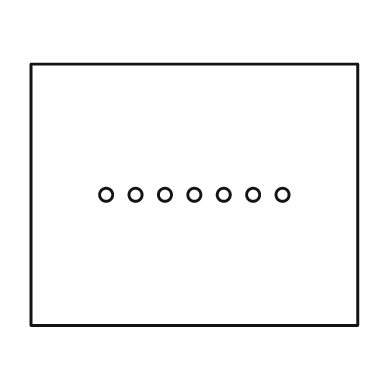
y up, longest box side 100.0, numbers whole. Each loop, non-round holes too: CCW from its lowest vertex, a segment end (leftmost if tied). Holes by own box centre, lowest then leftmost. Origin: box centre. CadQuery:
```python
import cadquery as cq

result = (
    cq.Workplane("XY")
    .moveTo(-50.0, -40.0)
    .lineTo(50.0, -40.0)
    .lineTo(50.0, 40.0)
    .lineTo(-50.0, 40.0)
    .close()
    .moveTo(-27.0, 0.0)
    .circle(2.0)
    .moveTo(-18.0, 0.0)
    .circle(2.0)
    .moveTo(-9.0, 0.0)
    .circle(2.0)
    .moveTo(0.0, 0.0)
    .circle(2.0)
    .moveTo(9.0, 0.0)
    .circle(2.0)
    .moveTo(18.0, 0.0)
    .circle(2.0)
    .moveTo(27.0, 0.0)
    .circle(2.0)
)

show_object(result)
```